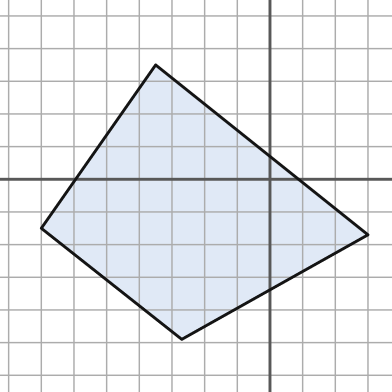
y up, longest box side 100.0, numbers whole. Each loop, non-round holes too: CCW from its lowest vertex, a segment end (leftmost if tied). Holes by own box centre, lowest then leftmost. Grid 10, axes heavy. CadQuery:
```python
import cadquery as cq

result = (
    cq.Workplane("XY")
    .moveTo(-27.0, -49.0)
    .lineTo(30.0, -17.0)
    .lineTo(-35.0, 35.0)
    .lineTo(-70.0, -15.0)
    .close()
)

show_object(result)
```